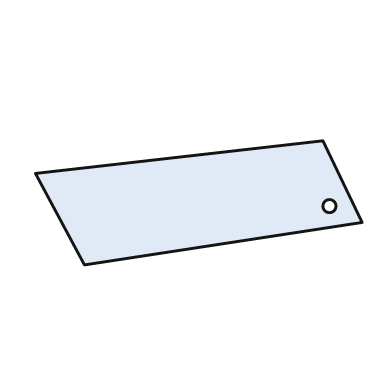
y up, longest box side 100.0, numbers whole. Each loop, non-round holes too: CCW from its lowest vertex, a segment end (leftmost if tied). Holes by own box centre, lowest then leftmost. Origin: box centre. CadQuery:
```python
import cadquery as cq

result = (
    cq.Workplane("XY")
    .moveTo(-35.0, -19.0)
    .lineTo(50.0, -6.0)
    .lineTo(38.0, 19.0)
    .lineTo(-50.0, 9.0)
    .close()
    .moveTo(40.0, -1.0)
    .circle(2.0)
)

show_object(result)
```